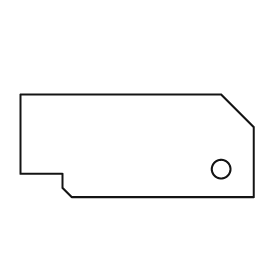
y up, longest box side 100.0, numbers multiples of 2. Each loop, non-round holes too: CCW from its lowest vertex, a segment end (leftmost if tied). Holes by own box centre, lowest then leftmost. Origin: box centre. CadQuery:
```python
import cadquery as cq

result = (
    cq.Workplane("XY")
    .moveTo(-28.0, -22.0)
    .lineTo(50.0, -22.0)
    .lineTo(50.0, 8.0)
    .lineTo(36.0, 22.0)
    .lineTo(-50.0, 22.0)
    .lineTo(-50.0, -12.0)
    .lineTo(-32.0, -12.0)
    .lineTo(-32.0, -18.0)
    .close()
    .moveTo(36.0, -10.0)
    .circle(4.0)
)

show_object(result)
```